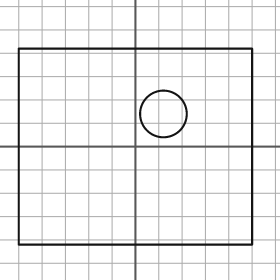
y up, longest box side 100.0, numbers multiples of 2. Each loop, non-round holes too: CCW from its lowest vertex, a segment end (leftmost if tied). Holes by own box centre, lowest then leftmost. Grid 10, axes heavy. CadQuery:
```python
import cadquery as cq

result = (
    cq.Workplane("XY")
    .moveTo(-50.0, -42.0)
    .lineTo(50.0, -42.0)
    .lineTo(50.0, 42.0)
    .lineTo(-50.0, 42.0)
    .close()
    .moveTo(12.0, 14.0)
    .circle(10.0)
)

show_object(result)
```